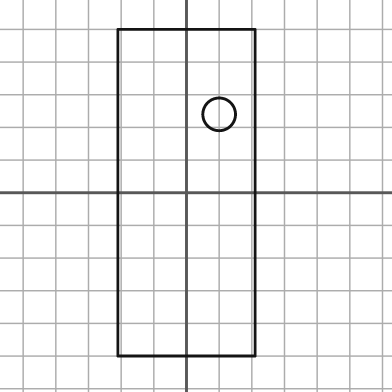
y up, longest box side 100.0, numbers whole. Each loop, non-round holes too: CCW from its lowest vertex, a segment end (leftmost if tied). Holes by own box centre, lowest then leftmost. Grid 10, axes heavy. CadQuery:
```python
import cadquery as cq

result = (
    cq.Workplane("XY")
    .moveTo(-21.0, -50.0)
    .lineTo(21.0, -50.0)
    .lineTo(21.0, 50.0)
    .lineTo(-21.0, 50.0)
    .close()
    .moveTo(10.0, 24.0)
    .circle(5.0)
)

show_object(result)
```